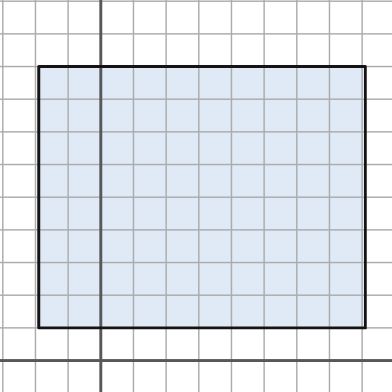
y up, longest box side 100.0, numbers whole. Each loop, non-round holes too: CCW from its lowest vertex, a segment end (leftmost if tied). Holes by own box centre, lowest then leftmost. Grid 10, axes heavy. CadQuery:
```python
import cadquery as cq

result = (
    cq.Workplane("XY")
    .moveTo(-19.0, 10.0)
    .lineTo(81.0, 10.0)
    .lineTo(81.0, 90.0)
    .lineTo(-19.0, 90.0)
    .close()
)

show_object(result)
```